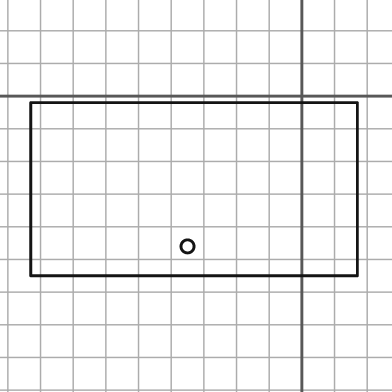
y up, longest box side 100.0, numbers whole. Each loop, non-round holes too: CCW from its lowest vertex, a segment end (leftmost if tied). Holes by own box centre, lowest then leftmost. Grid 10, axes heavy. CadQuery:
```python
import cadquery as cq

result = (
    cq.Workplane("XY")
    .moveTo(-83.0, -55.0)
    .lineTo(17.0, -55.0)
    .lineTo(17.0, -2.0)
    .lineTo(-83.0, -2.0)
    .close()
    .moveTo(-35.0, -46.0)
    .circle(2.0)
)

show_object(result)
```